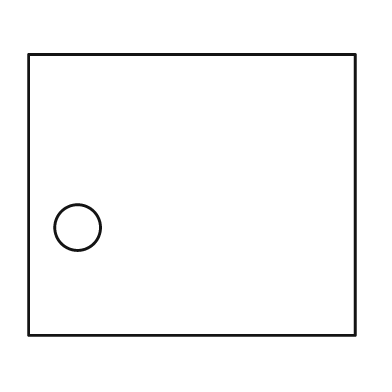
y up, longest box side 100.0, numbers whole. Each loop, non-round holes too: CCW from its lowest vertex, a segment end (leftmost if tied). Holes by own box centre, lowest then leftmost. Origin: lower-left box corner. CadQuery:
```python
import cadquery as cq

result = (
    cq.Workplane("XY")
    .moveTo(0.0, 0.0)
    .lineTo(100.0, 0.0)
    .lineTo(100.0, 86.0)
    .lineTo(0.0, 86.0)
    .close()
    .moveTo(15.0, 33.0)
    .circle(7.0)
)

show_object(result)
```